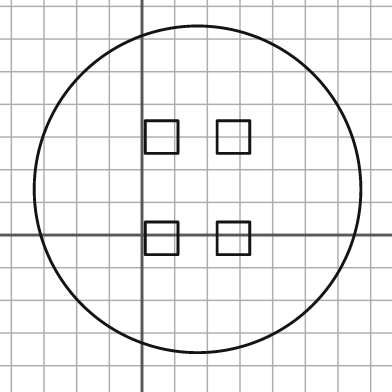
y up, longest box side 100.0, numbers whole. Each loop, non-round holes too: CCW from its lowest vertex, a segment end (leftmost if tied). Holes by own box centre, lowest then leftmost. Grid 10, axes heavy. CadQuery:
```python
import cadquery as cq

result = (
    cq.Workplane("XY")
    .moveTo(17.0, 14.0)
    .circle(50.0)
    .moveTo(1.0, -6.0)
    .lineTo(11.0, -6.0)
    .lineTo(11.0, 4.0)
    .lineTo(1.0, 4.0)
    .close()
    .moveTo(23.0, -6.0)
    .lineTo(33.0, -6.0)
    .lineTo(33.0, 4.0)
    .lineTo(23.0, 4.0)
    .close()
    .moveTo(1.0, 25.0)
    .lineTo(11.0, 25.0)
    .lineTo(11.0, 35.0)
    .lineTo(1.0, 35.0)
    .close()
    .moveTo(23.0, 25.0)
    .lineTo(33.0, 25.0)
    .lineTo(33.0, 35.0)
    .lineTo(23.0, 35.0)
    .close()
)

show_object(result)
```